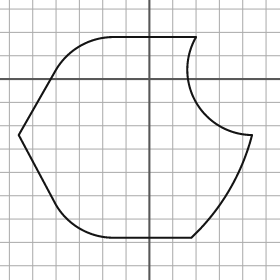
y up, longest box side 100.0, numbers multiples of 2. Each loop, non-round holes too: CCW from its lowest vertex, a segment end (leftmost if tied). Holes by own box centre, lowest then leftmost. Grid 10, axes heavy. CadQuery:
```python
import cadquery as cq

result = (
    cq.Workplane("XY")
    .moveTo(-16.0, -68.0)
    .lineTo(18.0, -68.0)
    .threePointArc((34.0, -48.0), (44.0, -24.0))
    .threePointArc((20.0, -10.0), (20.0, 18.0))
    .lineTo(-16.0, 18.0)
    .threePointArc((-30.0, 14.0), (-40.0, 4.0))
    .lineTo(-56.0, -24.0)
    .lineTo(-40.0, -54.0)
    .threePointArc((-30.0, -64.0), (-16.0, -68.0))
    .close()
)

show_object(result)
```